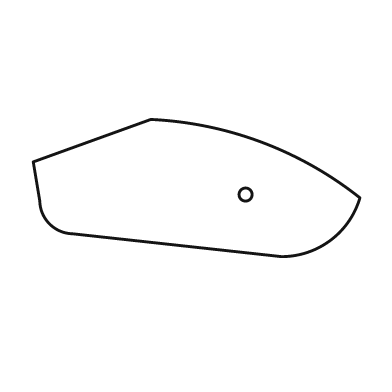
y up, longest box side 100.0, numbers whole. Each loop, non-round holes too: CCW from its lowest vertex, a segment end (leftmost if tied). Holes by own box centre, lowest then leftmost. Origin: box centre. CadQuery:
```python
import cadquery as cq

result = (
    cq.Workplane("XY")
    .moveTo(26.0, -21.0)
    .threePointArc((41.0, -16.0), (50.0, -3.0))
    .threePointArc((20.0, 14.0), (-14.0, 21.0))
    .lineTo(-50.0, 8.0)
    .lineTo(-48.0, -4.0)
    .threePointArc((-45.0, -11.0), (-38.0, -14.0))
    .close()
    .moveTo(15.0, -2.0)
    .circle(2.0)
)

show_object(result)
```